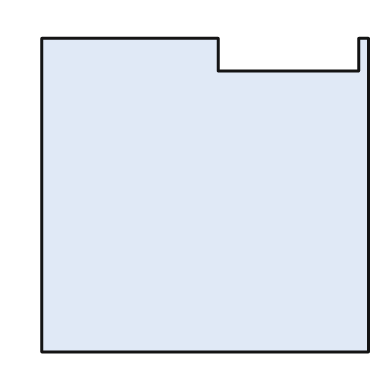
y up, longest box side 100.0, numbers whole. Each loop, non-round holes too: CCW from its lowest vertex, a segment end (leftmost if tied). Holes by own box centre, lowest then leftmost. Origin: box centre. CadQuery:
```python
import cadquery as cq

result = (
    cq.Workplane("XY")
    .moveTo(-50.0, -48.0)
    .lineTo(50.0, -48.0)
    .lineTo(50.0, 48.0)
    .lineTo(47.0, 48.0)
    .lineTo(47.0, 38.0)
    .lineTo(4.0, 38.0)
    .lineTo(4.0, 48.0)
    .lineTo(-50.0, 48.0)
    .close()
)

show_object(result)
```